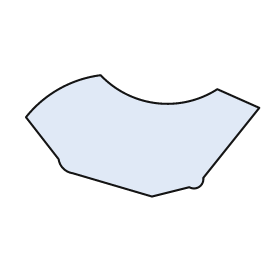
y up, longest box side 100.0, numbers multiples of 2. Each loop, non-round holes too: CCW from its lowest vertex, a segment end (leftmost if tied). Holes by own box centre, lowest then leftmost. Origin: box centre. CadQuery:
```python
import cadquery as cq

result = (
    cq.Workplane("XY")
    .moveTo(4.0, -26.0)
    .lineTo(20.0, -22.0)
    .threePointArc((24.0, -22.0), (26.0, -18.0))
    .lineTo(50.0, 12.0)
    .lineTo(32.0, 20.0)
    .threePointArc((6.0, 14.0), (-18.0, 26.0))
    .threePointArc((-36.0, 20.0), (-50.0, 8.0))
    .lineTo(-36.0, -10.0)
    .threePointArc((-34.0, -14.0), (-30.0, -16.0))
    .close()
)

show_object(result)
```